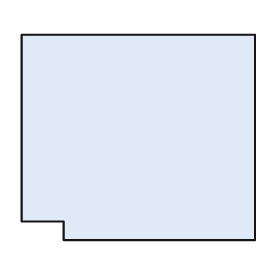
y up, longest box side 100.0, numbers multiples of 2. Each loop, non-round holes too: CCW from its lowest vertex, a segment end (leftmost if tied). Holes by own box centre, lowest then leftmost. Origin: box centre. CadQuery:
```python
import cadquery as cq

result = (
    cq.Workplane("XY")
    .moveTo(-32.0, -44.0)
    .lineTo(50.0, -44.0)
    .lineTo(50.0, 44.0)
    .lineTo(-50.0, 44.0)
    .lineTo(-50.0, -36.0)
    .lineTo(-32.0, -36.0)
    .close()
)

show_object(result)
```